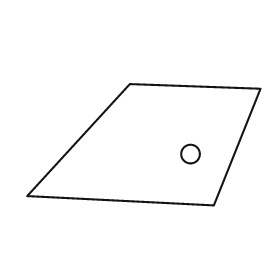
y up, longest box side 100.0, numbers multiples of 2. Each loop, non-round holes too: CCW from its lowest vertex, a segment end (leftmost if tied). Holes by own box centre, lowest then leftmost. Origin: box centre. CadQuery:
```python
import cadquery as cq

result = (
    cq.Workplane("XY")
    .moveTo(30.0, -26.0)
    .lineTo(50.0, 24.0)
    .lineTo(-6.0, 26.0)
    .lineTo(-50.0, -22.0)
    .close()
    .moveTo(20.0, -4.0)
    .circle(4.0)
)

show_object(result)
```